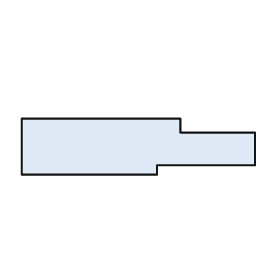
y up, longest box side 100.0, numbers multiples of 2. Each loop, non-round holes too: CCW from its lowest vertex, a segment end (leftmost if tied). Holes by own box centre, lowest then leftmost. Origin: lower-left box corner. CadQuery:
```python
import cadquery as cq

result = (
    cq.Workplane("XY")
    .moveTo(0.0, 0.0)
    .lineTo(58.0, 0.0)
    .lineTo(58.0, 4.0)
    .lineTo(100.0, 4.0)
    .lineTo(100.0, 18.0)
    .lineTo(68.0, 18.0)
    .lineTo(68.0, 24.0)
    .lineTo(0.0, 24.0)
    .close()
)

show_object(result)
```